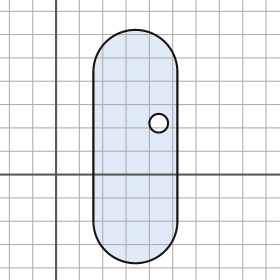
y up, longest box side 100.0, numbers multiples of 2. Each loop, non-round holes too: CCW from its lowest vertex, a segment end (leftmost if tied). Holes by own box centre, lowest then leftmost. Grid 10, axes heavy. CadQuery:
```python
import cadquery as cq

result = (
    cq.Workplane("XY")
    .moveTo(16.0, -20.0)
    .threePointArc((34.0, -38.0), (52.0, -20.0))
    .lineTo(52.0, 44.0)
    .threePointArc((34.0, 62.0), (16.0, 44.0))
    .close()
    .moveTo(44.0, 22.0)
    .circle(4.0)
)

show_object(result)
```